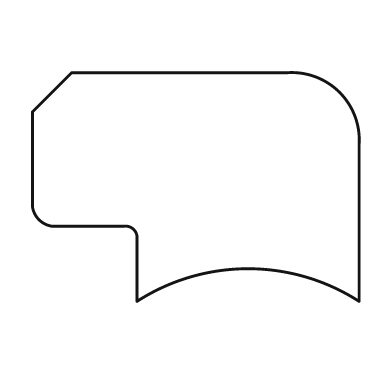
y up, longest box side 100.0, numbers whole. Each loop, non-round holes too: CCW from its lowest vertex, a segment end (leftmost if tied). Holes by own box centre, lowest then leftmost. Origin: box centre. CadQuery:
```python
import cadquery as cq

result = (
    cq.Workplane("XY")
    .moveTo(-18.0, -35.0)
    .threePointArc((16.0, -25.0), (50.0, -35.0))
    .lineTo(50.0, 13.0)
    .threePointArc((44.0, 29.0), (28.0, 35.0))
    .lineTo(-38.0, 35.0)
    .lineTo(-50.0, 23.0)
    .lineTo(-50.0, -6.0)
    .threePointArc((-48.0, -10.0), (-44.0, -12.0))
    .lineTo(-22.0, -12.0)
    .threePointArc((-19.0, -13.0), (-18.0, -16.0))
    .close()
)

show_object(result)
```